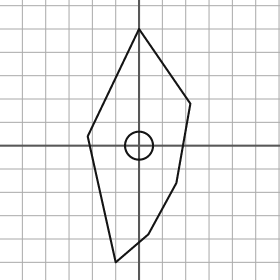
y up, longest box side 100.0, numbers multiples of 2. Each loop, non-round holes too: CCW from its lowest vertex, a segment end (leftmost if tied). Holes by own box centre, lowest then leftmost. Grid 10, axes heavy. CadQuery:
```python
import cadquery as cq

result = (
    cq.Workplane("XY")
    .moveTo(-10.0, -50.0)
    .lineTo(4.0, -38.0)
    .lineTo(16.0, -16.0)
    .lineTo(22.0, 18.0)
    .lineTo(0.0, 50.0)
    .lineTo(-22.0, 4.0)
    .close()
    .moveTo(0.0, 0.0)
    .circle(6.0)
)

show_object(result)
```